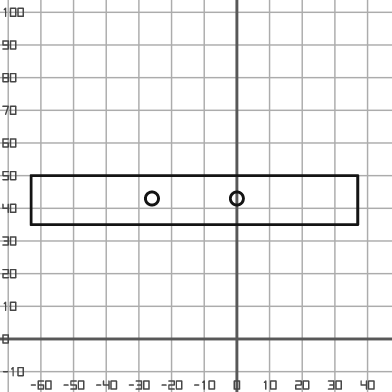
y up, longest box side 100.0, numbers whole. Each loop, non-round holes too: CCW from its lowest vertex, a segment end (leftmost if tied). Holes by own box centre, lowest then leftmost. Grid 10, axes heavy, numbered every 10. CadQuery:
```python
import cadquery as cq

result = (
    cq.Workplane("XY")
    .moveTo(-63.0, 35.0)
    .lineTo(37.0, 35.0)
    .lineTo(37.0, 50.0)
    .lineTo(-63.0, 50.0)
    .close()
    .moveTo(-26.0, 43.0)
    .circle(2.0)
    .moveTo(0.0, 43.0)
    .circle(2.0)
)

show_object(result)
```